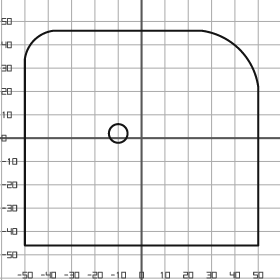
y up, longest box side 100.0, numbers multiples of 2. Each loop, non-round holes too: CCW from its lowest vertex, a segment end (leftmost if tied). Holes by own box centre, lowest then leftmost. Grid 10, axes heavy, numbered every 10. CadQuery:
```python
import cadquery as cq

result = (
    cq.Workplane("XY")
    .moveTo(-50.0, -46.0)
    .lineTo(50.0, -46.0)
    .lineTo(50.0, 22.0)
    .threePointArc((42.0, 38.0), (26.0, 46.0))
    .lineTo(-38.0, 46.0)
    .threePointArc((-46.0, 42.0), (-50.0, 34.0))
    .close()
    .moveTo(-10.0, 2.0)
    .circle(4.0)
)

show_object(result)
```